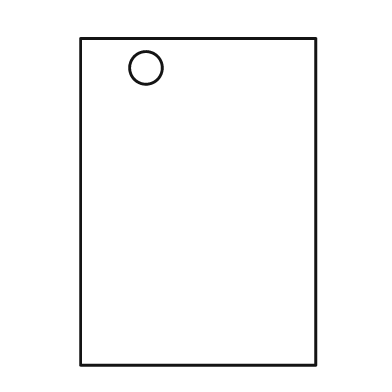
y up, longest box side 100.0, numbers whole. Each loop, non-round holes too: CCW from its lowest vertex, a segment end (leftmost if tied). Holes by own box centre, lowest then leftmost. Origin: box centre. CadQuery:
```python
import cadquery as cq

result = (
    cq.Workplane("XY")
    .moveTo(-36.0, -50.0)
    .lineTo(36.0, -50.0)
    .lineTo(36.0, 50.0)
    .lineTo(-36.0, 50.0)
    .close()
    .moveTo(-16.0, 41.0)
    .circle(5.0)
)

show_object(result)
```